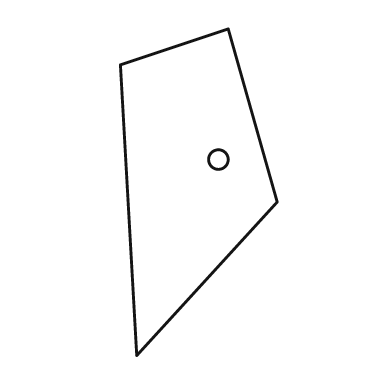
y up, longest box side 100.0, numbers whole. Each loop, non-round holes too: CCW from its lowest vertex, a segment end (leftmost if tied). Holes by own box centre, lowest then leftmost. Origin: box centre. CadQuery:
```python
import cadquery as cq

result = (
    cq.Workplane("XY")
    .moveTo(-19.0, -50.0)
    .lineTo(24.0, -3.0)
    .lineTo(9.0, 50.0)
    .lineTo(-24.0, 39.0)
    .close()
    .moveTo(6.0, 10.0)
    .circle(3.0)
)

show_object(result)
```